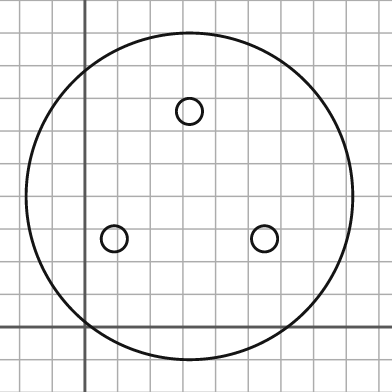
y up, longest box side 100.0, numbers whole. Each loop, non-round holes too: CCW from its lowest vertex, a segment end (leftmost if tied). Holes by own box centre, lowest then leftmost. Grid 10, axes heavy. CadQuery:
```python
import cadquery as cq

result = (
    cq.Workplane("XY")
    .moveTo(32.0, 40.0)
    .circle(50.0)
    .moveTo(9.0, 27.0)
    .circle(4.0)
    .moveTo(55.0, 27.0)
    .circle(4.0)
    .moveTo(32.0, 66.0)
    .circle(4.0)
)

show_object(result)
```